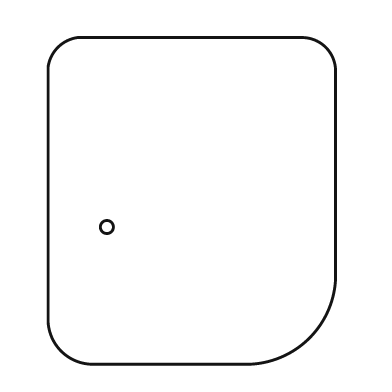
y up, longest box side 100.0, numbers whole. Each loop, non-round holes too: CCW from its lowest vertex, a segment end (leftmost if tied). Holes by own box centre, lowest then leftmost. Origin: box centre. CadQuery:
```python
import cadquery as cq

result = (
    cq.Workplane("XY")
    .moveTo(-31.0, -50.0)
    .lineTo(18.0, -50.0)
    .threePointArc((36.0, -42.0), (44.0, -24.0))
    .lineTo(44.0, 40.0)
    .threePointArc((41.0, 47.0), (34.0, 50.0))
    .lineTo(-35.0, 50.0)
    .threePointArc((-41.0, 47.0), (-44.0, 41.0))
    .lineTo(-44.0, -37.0)
    .threePointArc((-40.0, -46.0), (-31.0, -50.0))
    .close()
    .moveTo(-26.0, -8.0)
    .circle(2.0)
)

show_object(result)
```